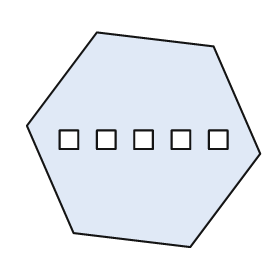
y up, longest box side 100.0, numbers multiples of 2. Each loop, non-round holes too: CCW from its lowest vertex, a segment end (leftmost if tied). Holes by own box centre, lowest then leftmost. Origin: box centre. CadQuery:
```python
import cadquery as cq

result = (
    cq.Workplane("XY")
    .moveTo(20.0, -46.0)
    .lineTo(50.0, -6.0)
    .lineTo(30.0, 40.0)
    .lineTo(-20.0, 46.0)
    .lineTo(-50.0, 6.0)
    .lineTo(-30.0, -40.0)
    .close()
    .moveTo(-36.0, -4.0)
    .lineTo(-28.0, -4.0)
    .lineTo(-28.0, 4.0)
    .lineTo(-36.0, 4.0)
    .close()
    .moveTo(-20.0, -4.0)
    .lineTo(-12.0, -4.0)
    .lineTo(-12.0, 4.0)
    .lineTo(-20.0, 4.0)
    .close()
    .moveTo(-4.0, -4.0)
    .lineTo(4.0, -4.0)
    .lineTo(4.0, 4.0)
    .lineTo(-4.0, 4.0)
    .close()
    .moveTo(12.0, -4.0)
    .lineTo(20.0, -4.0)
    .lineTo(20.0, 4.0)
    .lineTo(12.0, 4.0)
    .close()
    .moveTo(28.0, -4.0)
    .lineTo(36.0, -4.0)
    .lineTo(36.0, 4.0)
    .lineTo(28.0, 4.0)
    .close()
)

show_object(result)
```